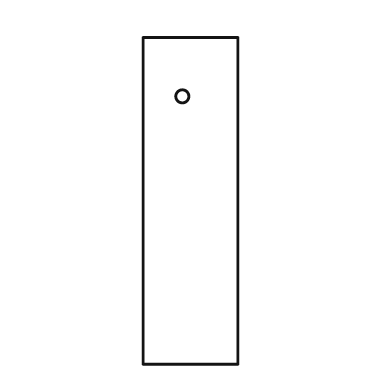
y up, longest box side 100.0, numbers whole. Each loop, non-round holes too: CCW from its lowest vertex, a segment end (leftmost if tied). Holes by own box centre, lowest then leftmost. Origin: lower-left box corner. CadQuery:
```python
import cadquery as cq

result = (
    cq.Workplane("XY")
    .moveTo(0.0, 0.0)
    .lineTo(29.0, 0.0)
    .lineTo(29.0, 100.0)
    .lineTo(0.0, 100.0)
    .close()
    .moveTo(12.0, 82.0)
    .circle(2.0)
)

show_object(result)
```